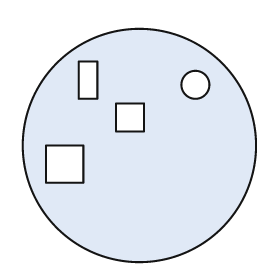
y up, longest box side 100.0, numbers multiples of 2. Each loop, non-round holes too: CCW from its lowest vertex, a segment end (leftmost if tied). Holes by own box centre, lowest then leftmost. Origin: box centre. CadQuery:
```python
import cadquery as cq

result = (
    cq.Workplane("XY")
    .moveTo(0.0, 0.0)
    .circle(50.0)
    .moveTo(-40.0, -16.0)
    .lineTo(-24.0, -16.0)
    .lineTo(-24.0, 0.0)
    .lineTo(-40.0, 0.0)
    .close()
    .moveTo(-10.0, 6.0)
    .lineTo(2.0, 6.0)
    .lineTo(2.0, 18.0)
    .lineTo(-10.0, 18.0)
    .close()
    .moveTo(24.0, 26.0)
    .circle(6.0)
    .moveTo(-26.0, 20.0)
    .lineTo(-18.0, 20.0)
    .lineTo(-18.0, 36.0)
    .lineTo(-26.0, 36.0)
    .close()
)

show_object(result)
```